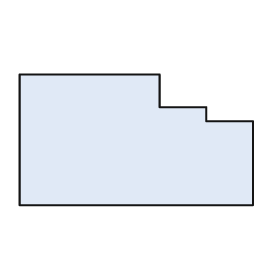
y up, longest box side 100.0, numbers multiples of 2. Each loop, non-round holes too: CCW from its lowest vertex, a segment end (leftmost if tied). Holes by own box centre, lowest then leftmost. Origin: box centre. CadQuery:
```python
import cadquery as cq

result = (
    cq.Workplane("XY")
    .moveTo(-50.0, -28.0)
    .lineTo(50.0, -28.0)
    .lineTo(50.0, 8.0)
    .lineTo(30.0, 8.0)
    .lineTo(30.0, 14.0)
    .lineTo(10.0, 14.0)
    .lineTo(10.0, 28.0)
    .lineTo(-50.0, 28.0)
    .close()
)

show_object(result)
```